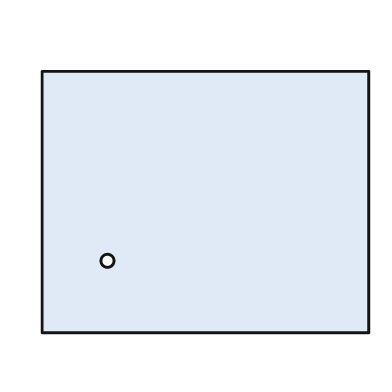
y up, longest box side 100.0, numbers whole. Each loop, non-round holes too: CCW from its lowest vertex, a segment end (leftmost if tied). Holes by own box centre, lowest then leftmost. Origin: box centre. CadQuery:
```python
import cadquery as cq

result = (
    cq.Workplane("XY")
    .moveTo(-50.0, -40.0)
    .lineTo(50.0, -40.0)
    .lineTo(50.0, 40.0)
    .lineTo(-50.0, 40.0)
    .close()
    .moveTo(-30.0, -18.0)
    .circle(2.0)
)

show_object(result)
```